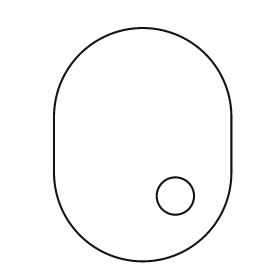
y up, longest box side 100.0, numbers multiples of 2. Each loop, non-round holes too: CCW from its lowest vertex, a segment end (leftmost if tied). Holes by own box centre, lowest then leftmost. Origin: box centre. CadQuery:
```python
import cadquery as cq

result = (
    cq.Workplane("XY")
    .moveTo(-38.0, -12.0)
    .threePointArc((0.0, -50.0), (38.0, -12.0))
    .lineTo(38.0, 12.0)
    .threePointArc((0.0, 50.0), (-38.0, 12.0))
    .close()
    .moveTo(14.0, -22.0)
    .circle(8.0)
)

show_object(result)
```